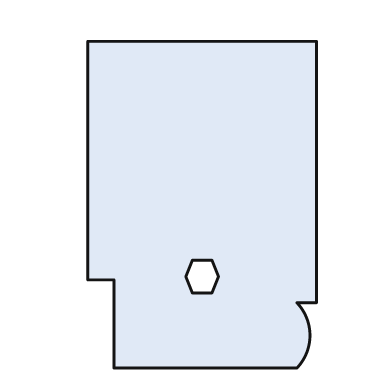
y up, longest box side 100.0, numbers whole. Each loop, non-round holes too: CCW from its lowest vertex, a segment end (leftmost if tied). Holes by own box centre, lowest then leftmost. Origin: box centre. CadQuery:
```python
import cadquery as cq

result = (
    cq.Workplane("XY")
    .moveTo(-27.0, -50.0)
    .lineTo(29.0, -50.0)
    .threePointArc((33.0, -40.0), (29.0, -30.0))
    .lineTo(35.0, -30.0)
    .lineTo(35.0, 50.0)
    .lineTo(-35.0, 50.0)
    .lineTo(-35.0, -23.0)
    .lineTo(-27.0, -23.0)
    .close()
    .moveTo(-3.0, -27.0)
    .lineTo(3.0, -27.0)
    .lineTo(5.0, -22.0)
    .lineTo(3.0, -17.0)
    .lineTo(-3.0, -17.0)
    .lineTo(-5.0, -22.0)
    .close()
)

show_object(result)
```